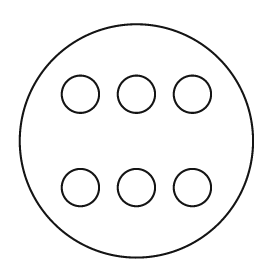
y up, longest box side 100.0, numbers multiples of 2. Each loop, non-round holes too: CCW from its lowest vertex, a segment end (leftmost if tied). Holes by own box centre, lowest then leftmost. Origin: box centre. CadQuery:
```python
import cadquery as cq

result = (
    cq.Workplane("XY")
    .moveTo(0.0, 0.0)
    .circle(50.0)
    .moveTo(-24.0, -20.0)
    .circle(8.0)
    .moveTo(0.0, -20.0)
    .circle(8.0)
    .moveTo(24.0, -20.0)
    .circle(8.0)
    .moveTo(-24.0, 20.0)
    .circle(8.0)
    .moveTo(0.0, 20.0)
    .circle(8.0)
    .moveTo(24.0, 20.0)
    .circle(8.0)
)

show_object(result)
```